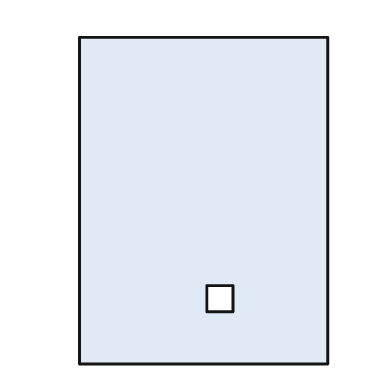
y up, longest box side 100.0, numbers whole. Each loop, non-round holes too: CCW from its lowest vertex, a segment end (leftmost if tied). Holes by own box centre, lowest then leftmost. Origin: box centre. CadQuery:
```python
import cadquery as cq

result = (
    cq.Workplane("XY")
    .moveTo(-38.0, -50.0)
    .lineTo(38.0, -50.0)
    .lineTo(38.0, 50.0)
    .lineTo(-38.0, 50.0)
    .close()
    .moveTo(1.0, -34.0)
    .lineTo(9.0, -34.0)
    .lineTo(9.0, -26.0)
    .lineTo(1.0, -26.0)
    .close()
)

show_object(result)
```